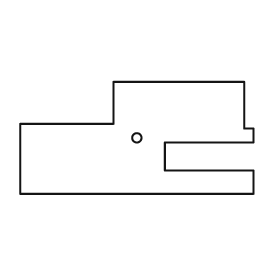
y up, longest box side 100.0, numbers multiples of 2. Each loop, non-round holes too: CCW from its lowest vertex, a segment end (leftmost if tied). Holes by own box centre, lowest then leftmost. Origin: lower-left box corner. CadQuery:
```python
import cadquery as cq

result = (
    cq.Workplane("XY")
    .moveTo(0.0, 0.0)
    .lineTo(100.0, 0.0)
    .lineTo(100.0, 10.0)
    .lineTo(62.0, 10.0)
    .lineTo(62.0, 22.0)
    .lineTo(100.0, 22.0)
    .lineTo(100.0, 28.0)
    .lineTo(96.0, 28.0)
    .lineTo(96.0, 48.0)
    .lineTo(40.0, 48.0)
    .lineTo(40.0, 30.0)
    .lineTo(0.0, 30.0)
    .close()
    .moveTo(50.0, 24.0)
    .circle(2.0)
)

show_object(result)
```